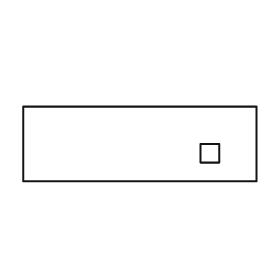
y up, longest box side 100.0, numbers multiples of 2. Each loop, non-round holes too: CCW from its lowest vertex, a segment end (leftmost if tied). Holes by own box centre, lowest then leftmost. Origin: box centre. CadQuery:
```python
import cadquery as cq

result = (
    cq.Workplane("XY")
    .moveTo(-50.0, -16.0)
    .lineTo(50.0, -16.0)
    .lineTo(50.0, 16.0)
    .lineTo(-50.0, 16.0)
    .close()
    .moveTo(26.0, -8.0)
    .lineTo(34.0, -8.0)
    .lineTo(34.0, 0.0)
    .lineTo(26.0, 0.0)
    .close()
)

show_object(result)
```